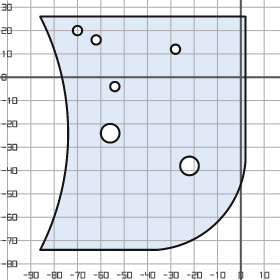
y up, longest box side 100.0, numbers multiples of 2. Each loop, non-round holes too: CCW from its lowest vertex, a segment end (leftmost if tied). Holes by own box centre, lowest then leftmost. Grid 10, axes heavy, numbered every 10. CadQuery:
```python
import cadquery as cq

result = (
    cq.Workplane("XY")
    .moveTo(-86.0, -74.0)
    .lineTo(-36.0, -74.0)
    .threePointArc((-10.0, -62.0), (2.0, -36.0))
    .lineTo(2.0, 26.0)
    .lineTo(-86.0, 26.0)
    .threePointArc((-74.0, -24.0), (-86.0, -74.0))
    .close()
    .moveTo(-22.0, -38.0)
    .circle(4.0)
    .moveTo(-56.0, -24.0)
    .circle(4.0)
    .moveTo(-54.0, -4.0)
    .circle(2.0)
    .moveTo(-28.0, 12.0)
    .circle(2.0)
    .moveTo(-62.0, 16.0)
    .circle(2.0)
    .moveTo(-70.0, 20.0)
    .circle(2.0)
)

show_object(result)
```